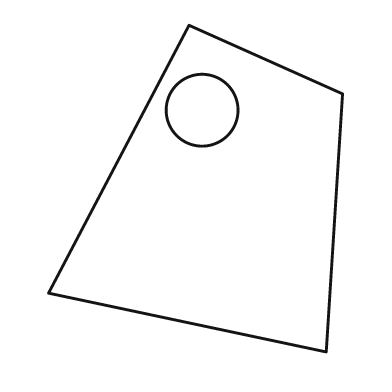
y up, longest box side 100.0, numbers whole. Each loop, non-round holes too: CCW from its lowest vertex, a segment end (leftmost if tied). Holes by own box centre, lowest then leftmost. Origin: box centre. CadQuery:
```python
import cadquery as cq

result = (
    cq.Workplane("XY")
    .moveTo(40.0, -50.0)
    .lineTo(45.0, 29.0)
    .lineTo(-2.0, 50.0)
    .lineTo(-45.0, -32.0)
    .close()
    .moveTo(2.0, 24.0)
    .circle(11.0)
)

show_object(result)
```